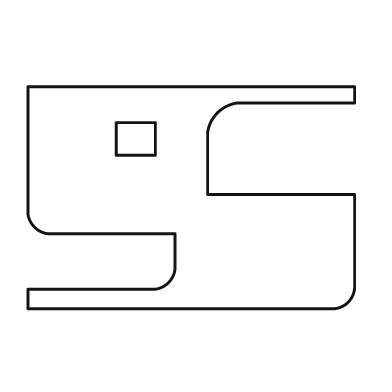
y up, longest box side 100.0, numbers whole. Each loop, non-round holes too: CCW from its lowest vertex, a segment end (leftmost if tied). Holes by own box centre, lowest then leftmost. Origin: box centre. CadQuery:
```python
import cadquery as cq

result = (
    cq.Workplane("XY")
    .moveTo(-50.0, -34.0)
    .lineTo(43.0, -34.0)
    .threePointArc((48.0, -32.0), (50.0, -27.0))
    .lineTo(50.0, 1.0)
    .lineTo(5.0, 1.0)
    .lineTo(5.0, 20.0)
    .threePointArc((8.0, 26.0), (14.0, 29.0))
    .lineTo(50.0, 29.0)
    .lineTo(50.0, 34.0)
    .lineTo(-50.0, 34.0)
    .lineTo(-50.0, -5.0)
    .threePointArc((-48.0, -9.0), (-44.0, -11.0))
    .lineTo(-5.0, -11.0)
    .lineTo(-5.0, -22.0)
    .threePointArc((-7.0, -26.0), (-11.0, -28.0))
    .lineTo(-50.0, -28.0)
    .close()
    .moveTo(-23.0, 13.0)
    .lineTo(-11.0, 13.0)
    .lineTo(-11.0, 23.0)
    .lineTo(-23.0, 23.0)
    .close()
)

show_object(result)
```